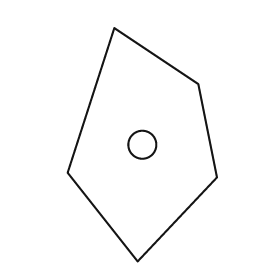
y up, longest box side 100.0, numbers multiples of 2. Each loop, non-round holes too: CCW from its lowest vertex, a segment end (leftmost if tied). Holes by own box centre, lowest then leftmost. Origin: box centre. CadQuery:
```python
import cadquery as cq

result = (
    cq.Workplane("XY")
    .moveTo(-2.0, -50.0)
    .lineTo(32.0, -14.0)
    .lineTo(24.0, 26.0)
    .lineTo(-12.0, 50.0)
    .lineTo(-32.0, -12.0)
    .close()
    .moveTo(0.0, 0.0)
    .circle(6.0)
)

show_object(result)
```